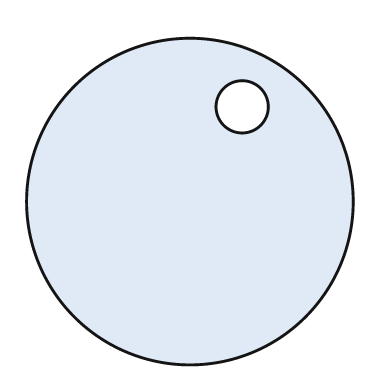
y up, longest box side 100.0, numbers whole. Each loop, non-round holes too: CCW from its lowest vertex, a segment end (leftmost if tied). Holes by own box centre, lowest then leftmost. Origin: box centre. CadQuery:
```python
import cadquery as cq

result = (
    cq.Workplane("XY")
    .moveTo(0.0, 0.0)
    .circle(50.0)
    .moveTo(16.0, 29.0)
    .circle(8.0)
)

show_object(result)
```